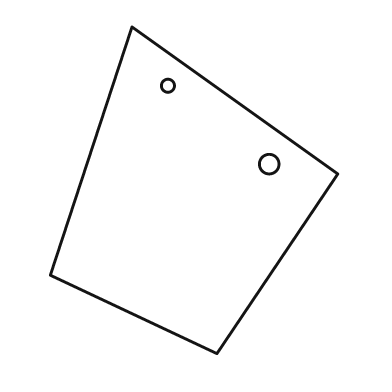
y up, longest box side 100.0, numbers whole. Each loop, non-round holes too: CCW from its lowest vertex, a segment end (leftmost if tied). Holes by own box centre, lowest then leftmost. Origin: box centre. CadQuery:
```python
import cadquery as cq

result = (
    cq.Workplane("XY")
    .moveTo(7.0, -50.0)
    .lineTo(44.0, 5.0)
    .lineTo(-19.0, 50.0)
    .lineTo(-44.0, -26.0)
    .close()
    .moveTo(23.0, 8.0)
    .circle(3.0)
    .moveTo(-8.0, 32.0)
    .circle(2.0)
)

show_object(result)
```